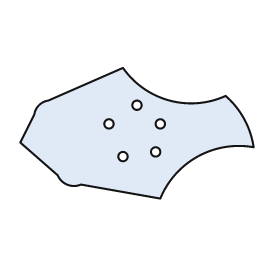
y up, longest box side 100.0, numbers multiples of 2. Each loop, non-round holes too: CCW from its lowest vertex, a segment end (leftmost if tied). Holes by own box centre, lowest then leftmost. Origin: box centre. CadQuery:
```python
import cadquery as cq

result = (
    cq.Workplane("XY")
    .moveTo(10.0, -28.0)
    .threePointArc((26.0, -10.0), (50.0, -6.0))
    .threePointArc((46.0, 6.0), (38.0, 16.0))
    .threePointArc((14.0, 14.0), (-6.0, 28.0))
    .lineTo(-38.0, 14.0)
    .threePointArc((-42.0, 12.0), (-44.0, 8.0))
    .lineTo(-50.0, -4.0)
    .lineTo(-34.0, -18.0)
    .threePointArc((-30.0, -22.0), (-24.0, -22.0))
    .close()
    .moveTo(-6.0, -10.0)
    .circle(2.0)
    .moveTo(8.0, -8.0)
    .circle(2.0)
    .moveTo(-12.0, 4.0)
    .circle(2.0)
    .moveTo(10.0, 4.0)
    .circle(2.0)
    .moveTo(0.0, 12.0)
    .circle(2.0)
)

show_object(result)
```